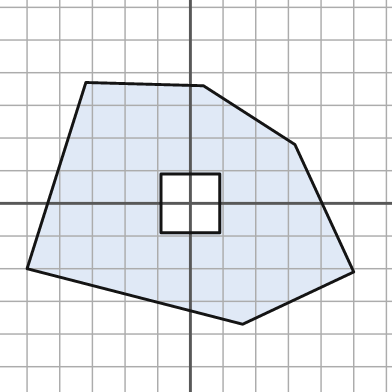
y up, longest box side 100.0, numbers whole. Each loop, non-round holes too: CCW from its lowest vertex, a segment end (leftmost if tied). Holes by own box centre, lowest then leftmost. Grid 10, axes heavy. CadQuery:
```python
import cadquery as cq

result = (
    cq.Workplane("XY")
    .moveTo(16.0, -37.0)
    .lineTo(50.0, -21.0)
    .lineTo(32.0, 18.0)
    .lineTo(4.0, 36.0)
    .lineTo(-32.0, 37.0)
    .lineTo(-50.0, -20.0)
    .close()
    .moveTo(-9.0, -9.0)
    .lineTo(9.0, -9.0)
    .lineTo(9.0, 9.0)
    .lineTo(-9.0, 9.0)
    .close()
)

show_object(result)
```